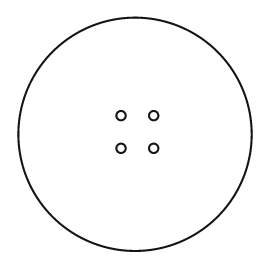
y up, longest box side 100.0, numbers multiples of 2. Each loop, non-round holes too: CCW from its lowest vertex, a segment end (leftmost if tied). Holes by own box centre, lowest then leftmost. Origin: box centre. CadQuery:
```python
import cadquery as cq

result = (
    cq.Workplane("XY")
    .moveTo(0.0, 0.0)
    .circle(50.0)
    .moveTo(-6.0, -6.0)
    .circle(2.0)
    .moveTo(8.0, -6.0)
    .circle(2.0)
    .moveTo(-6.0, 8.0)
    .circle(2.0)
    .moveTo(8.0, 8.0)
    .circle(2.0)
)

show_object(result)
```